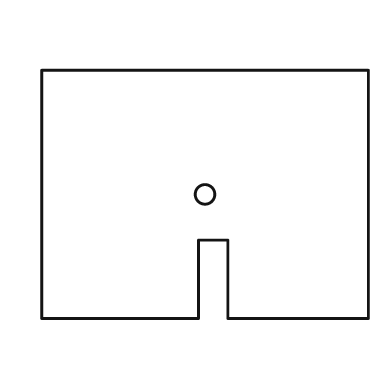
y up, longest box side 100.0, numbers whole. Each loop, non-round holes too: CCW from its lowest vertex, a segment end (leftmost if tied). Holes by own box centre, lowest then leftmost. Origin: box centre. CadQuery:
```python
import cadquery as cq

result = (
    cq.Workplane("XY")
    .moveTo(-50.0, -38.0)
    .lineTo(-2.0, -38.0)
    .lineTo(-2.0, -14.0)
    .lineTo(7.0, -14.0)
    .lineTo(7.0, -38.0)
    .lineTo(50.0, -38.0)
    .lineTo(50.0, 38.0)
    .lineTo(-50.0, 38.0)
    .close()
    .moveTo(0.0, 0.0)
    .circle(3.0)
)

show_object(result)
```